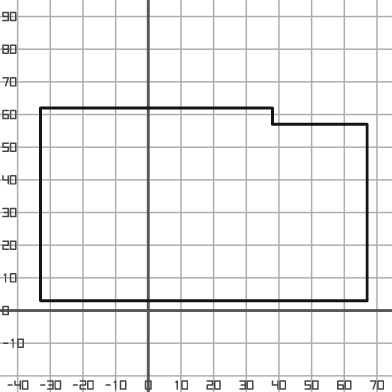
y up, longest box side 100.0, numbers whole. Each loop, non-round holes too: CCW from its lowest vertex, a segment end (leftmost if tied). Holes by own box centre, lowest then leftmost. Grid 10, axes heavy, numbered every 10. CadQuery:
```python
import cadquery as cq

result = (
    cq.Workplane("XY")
    .moveTo(-33.0, 3.0)
    .lineTo(67.0, 3.0)
    .lineTo(67.0, 57.0)
    .lineTo(38.0, 57.0)
    .lineTo(38.0, 62.0)
    .lineTo(-33.0, 62.0)
    .close()
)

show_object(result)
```